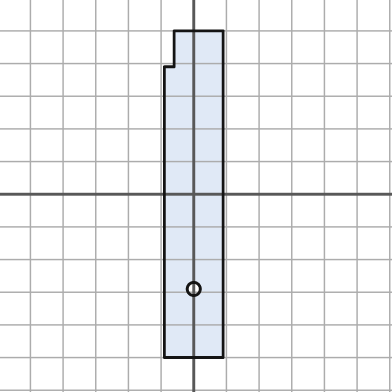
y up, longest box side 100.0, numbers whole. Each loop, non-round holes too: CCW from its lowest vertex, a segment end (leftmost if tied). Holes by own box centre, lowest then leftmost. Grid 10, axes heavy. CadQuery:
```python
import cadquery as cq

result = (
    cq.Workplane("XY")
    .moveTo(-9.0, -50.0)
    .lineTo(9.0, -50.0)
    .lineTo(9.0, 50.0)
    .lineTo(-6.0, 50.0)
    .lineTo(-6.0, 39.0)
    .lineTo(-9.0, 39.0)
    .close()
    .moveTo(0.0, -29.0)
    .circle(2.0)
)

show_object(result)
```